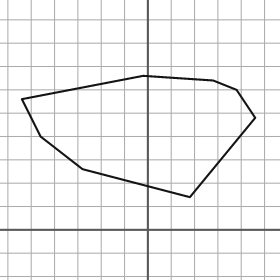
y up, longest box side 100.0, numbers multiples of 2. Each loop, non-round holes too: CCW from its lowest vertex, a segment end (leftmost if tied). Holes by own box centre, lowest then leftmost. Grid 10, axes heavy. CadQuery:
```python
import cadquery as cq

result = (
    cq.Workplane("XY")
    .moveTo(18.0, 14.0)
    .lineTo(46.0, 48.0)
    .lineTo(38.0, 60.0)
    .lineTo(28.0, 64.0)
    .lineTo(-2.0, 66.0)
    .lineTo(-54.0, 56.0)
    .lineTo(-46.0, 40.0)
    .lineTo(-28.0, 26.0)
    .close()
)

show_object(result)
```